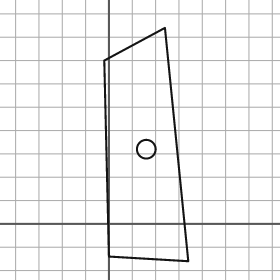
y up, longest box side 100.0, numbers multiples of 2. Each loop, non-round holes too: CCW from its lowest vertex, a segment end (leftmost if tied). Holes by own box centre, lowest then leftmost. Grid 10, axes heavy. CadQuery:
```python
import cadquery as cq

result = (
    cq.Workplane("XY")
    .moveTo(34.0, -16.0)
    .lineTo(24.0, 84.0)
    .lineTo(-2.0, 70.0)
    .lineTo(0.0, -14.0)
    .close()
    .moveTo(16.0, 32.0)
    .circle(4.0)
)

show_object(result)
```